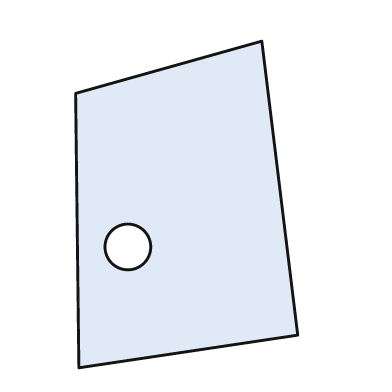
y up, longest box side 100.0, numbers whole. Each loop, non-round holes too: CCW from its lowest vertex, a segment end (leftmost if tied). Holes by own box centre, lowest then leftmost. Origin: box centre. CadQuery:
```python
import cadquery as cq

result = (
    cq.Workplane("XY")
    .moveTo(-33.0, -50.0)
    .lineTo(34.0, -40.0)
    .lineTo(23.0, 50.0)
    .lineTo(-34.0, 34.0)
    .close()
    .moveTo(-18.0, -13.0)
    .circle(7.0)
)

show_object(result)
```